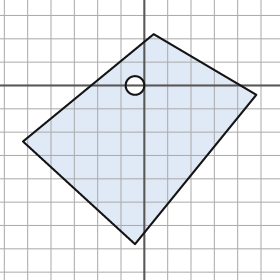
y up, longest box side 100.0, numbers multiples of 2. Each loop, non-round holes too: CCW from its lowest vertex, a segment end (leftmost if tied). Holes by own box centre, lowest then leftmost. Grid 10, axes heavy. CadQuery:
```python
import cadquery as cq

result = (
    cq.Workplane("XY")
    .moveTo(-4.0, -68.0)
    .lineTo(48.0, -4.0)
    .lineTo(4.0, 22.0)
    .lineTo(-52.0, -24.0)
    .close()
    .moveTo(-4.0, 0.0)
    .circle(4.0)
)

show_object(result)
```